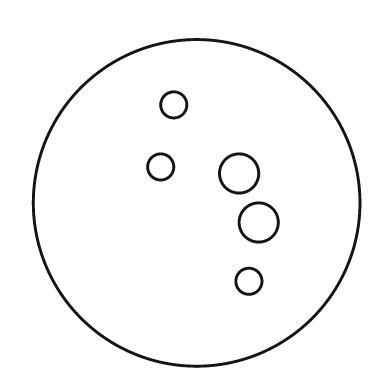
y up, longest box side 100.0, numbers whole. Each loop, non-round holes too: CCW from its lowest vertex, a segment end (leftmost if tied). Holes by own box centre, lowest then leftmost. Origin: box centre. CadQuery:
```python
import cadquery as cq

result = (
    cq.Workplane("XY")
    .moveTo(0.0, 0.0)
    .circle(50.0)
    .moveTo(16.0, -24.0)
    .circle(4.0)
    .moveTo(19.0, -6.0)
    .circle(6.0)
    .moveTo(13.0, 9.0)
    .circle(6.0)
    .moveTo(-11.0, 11.0)
    .circle(4.0)
    .moveTo(-7.0, 30.0)
    .circle(4.0)
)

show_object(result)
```